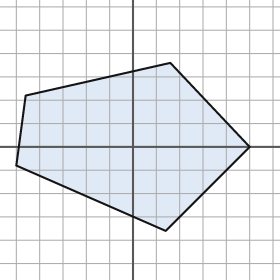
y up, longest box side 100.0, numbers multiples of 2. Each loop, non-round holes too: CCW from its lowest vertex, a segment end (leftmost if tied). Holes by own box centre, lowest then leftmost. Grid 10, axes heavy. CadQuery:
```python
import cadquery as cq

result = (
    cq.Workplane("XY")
    .moveTo(14.0, -36.0)
    .lineTo(50.0, 0.0)
    .lineTo(16.0, 36.0)
    .lineTo(-46.0, 22.0)
    .lineTo(-50.0, -8.0)
    .close()
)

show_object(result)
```